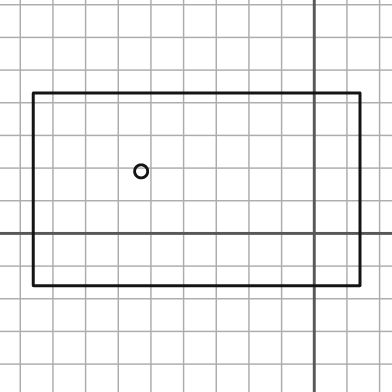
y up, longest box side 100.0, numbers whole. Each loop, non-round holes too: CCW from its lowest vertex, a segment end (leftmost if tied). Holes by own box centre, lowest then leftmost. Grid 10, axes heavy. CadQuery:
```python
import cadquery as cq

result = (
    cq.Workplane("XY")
    .moveTo(-86.0, -16.0)
    .lineTo(14.0, -16.0)
    .lineTo(14.0, 43.0)
    .lineTo(-86.0, 43.0)
    .close()
    .moveTo(-53.0, 19.0)
    .circle(2.0)
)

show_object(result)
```